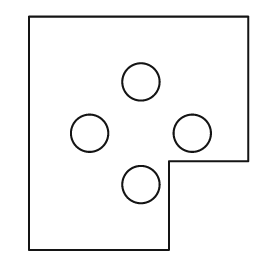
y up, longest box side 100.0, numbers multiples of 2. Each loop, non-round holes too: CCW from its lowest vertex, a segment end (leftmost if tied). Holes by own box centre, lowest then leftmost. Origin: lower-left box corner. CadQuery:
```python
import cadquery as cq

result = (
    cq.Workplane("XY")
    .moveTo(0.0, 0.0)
    .lineTo(60.0, 0.0)
    .lineTo(60.0, 38.0)
    .lineTo(94.0, 38.0)
    .lineTo(94.0, 100.0)
    .lineTo(0.0, 100.0)
    .close()
    .moveTo(48.0, 28.0)
    .circle(8.0)
    .moveTo(26.0, 50.0)
    .circle(8.0)
    .moveTo(70.0, 50.0)
    .circle(8.0)
    .moveTo(48.0, 72.0)
    .circle(8.0)
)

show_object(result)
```